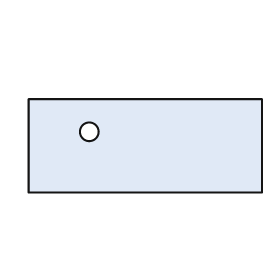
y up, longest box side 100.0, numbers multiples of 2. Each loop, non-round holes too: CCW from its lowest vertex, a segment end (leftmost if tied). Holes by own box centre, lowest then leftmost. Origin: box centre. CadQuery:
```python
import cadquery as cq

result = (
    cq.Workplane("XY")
    .moveTo(-50.0, -20.0)
    .lineTo(50.0, -20.0)
    .lineTo(50.0, 20.0)
    .lineTo(-50.0, 20.0)
    .close()
    .moveTo(-24.0, 6.0)
    .circle(4.0)
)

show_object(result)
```